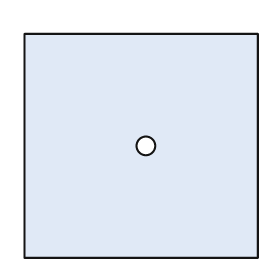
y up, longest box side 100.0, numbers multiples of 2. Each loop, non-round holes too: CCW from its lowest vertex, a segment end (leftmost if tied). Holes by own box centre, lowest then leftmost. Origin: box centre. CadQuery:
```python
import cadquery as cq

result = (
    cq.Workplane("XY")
    .moveTo(-50.0, -48.0)
    .lineTo(50.0, -48.0)
    .lineTo(50.0, 48.0)
    .lineTo(-50.0, 48.0)
    .close()
    .moveTo(2.0, 0.0)
    .circle(4.0)
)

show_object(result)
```